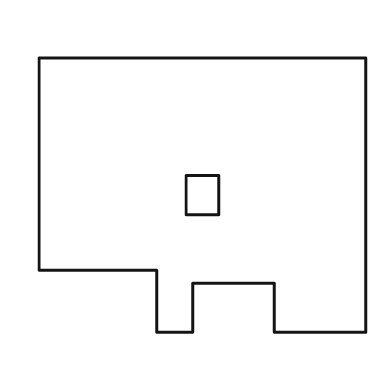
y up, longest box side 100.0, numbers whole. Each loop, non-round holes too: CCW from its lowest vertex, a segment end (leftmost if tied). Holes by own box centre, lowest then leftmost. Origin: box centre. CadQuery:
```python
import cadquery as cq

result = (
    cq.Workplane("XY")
    .moveTo(-14.0, -42.0)
    .lineTo(-3.0, -42.0)
    .lineTo(-3.0, -27.0)
    .lineTo(22.0, -27.0)
    .lineTo(22.0, -42.0)
    .lineTo(50.0, -42.0)
    .lineTo(50.0, 42.0)
    .lineTo(-50.0, 42.0)
    .lineTo(-50.0, -23.0)
    .lineTo(-14.0, -23.0)
    .close()
    .moveTo(-5.0, -6.0)
    .lineTo(5.0, -6.0)
    .lineTo(5.0, 6.0)
    .lineTo(-5.0, 6.0)
    .close()
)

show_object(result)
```